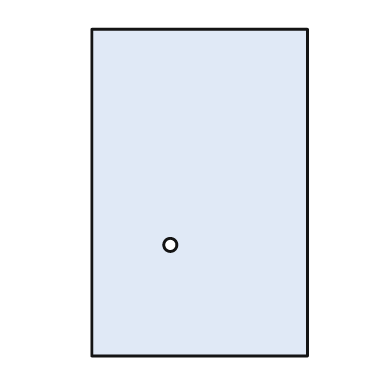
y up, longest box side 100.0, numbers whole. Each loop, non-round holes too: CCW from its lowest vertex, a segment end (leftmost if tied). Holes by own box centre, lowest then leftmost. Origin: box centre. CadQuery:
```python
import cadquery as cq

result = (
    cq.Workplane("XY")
    .moveTo(-33.0, -50.0)
    .lineTo(33.0, -50.0)
    .lineTo(33.0, 50.0)
    .lineTo(-33.0, 50.0)
    .close()
    .moveTo(-9.0, -16.0)
    .circle(2.0)
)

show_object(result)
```